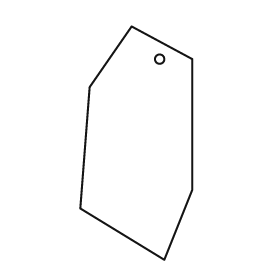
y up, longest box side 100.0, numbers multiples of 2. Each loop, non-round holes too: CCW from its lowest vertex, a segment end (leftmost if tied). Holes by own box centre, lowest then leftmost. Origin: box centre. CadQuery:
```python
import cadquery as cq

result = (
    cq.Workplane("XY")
    .moveTo(12.0, -50.0)
    .lineTo(24.0, -20.0)
    .lineTo(24.0, 36.0)
    .lineTo(-2.0, 50.0)
    .lineTo(-20.0, 24.0)
    .lineTo(-24.0, -28.0)
    .close()
    .moveTo(10.0, 36.0)
    .circle(2.0)
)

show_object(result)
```